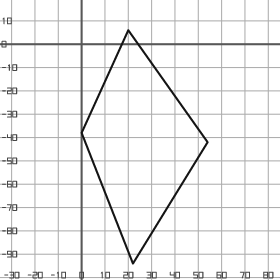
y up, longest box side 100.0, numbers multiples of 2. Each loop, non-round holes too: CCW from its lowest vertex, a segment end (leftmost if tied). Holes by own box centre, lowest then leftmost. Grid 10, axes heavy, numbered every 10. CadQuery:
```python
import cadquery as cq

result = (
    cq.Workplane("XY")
    .moveTo(22.0, -94.0)
    .lineTo(54.0, -42.0)
    .lineTo(20.0, 6.0)
    .lineTo(0.0, -38.0)
    .close()
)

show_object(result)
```